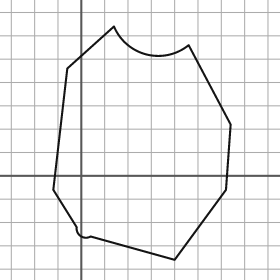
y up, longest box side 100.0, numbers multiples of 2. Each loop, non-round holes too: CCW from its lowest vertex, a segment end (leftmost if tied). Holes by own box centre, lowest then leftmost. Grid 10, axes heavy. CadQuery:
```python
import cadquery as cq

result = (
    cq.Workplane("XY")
    .moveTo(40.0, -36.0)
    .lineTo(62.0, -6.0)
    .lineTo(64.0, 22.0)
    .lineTo(46.0, 56.0)
    .threePointArc((28.0, 52.0), (14.0, 64.0))
    .lineTo(-6.0, 46.0)
    .lineTo(-12.0, -6.0)
    .lineTo(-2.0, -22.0)
    .threePointArc((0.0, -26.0), (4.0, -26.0))
    .close()
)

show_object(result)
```